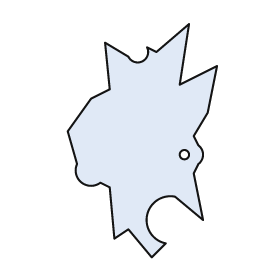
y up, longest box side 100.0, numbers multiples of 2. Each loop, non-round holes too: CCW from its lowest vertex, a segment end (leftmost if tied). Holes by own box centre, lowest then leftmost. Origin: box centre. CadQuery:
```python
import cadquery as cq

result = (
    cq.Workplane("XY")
    .moveTo(4.0, -50.0)
    .lineTo(10.0, -44.0)
    .threePointArc((2.0, -32.0), (14.0, -24.0))
    .lineTo(26.0, -34.0)
    .lineTo(22.0, -14.0)
    .lineTo(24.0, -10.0)
    .threePointArc((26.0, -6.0), (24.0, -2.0))
    .lineTo(22.0, 2.0)
    .lineTo(28.0, 12.0)
    .lineTo(32.0, 32.0)
    .lineTo(16.0, 24.0)
    .lineTo(20.0, 50.0)
    .lineTo(6.0, 38.0)
    .lineTo(2.0, 40.0)
    .threePointArc((0.0, 34.0), (-6.0, 36.0))
    .lineTo(-16.0, 42.0)
    .lineTo(-14.0, 22.0)
    .lineTo(-22.0, 18.0)
    .lineTo(-32.0, 4.0)
    .lineTo(-28.0, -10.0)
    .threePointArc((-26.0, -18.0), (-18.0, -18.0))
    .lineTo(-14.0, -20.0)
    .lineTo(-12.0, -42.0)
    .lineTo(-6.0, -38.0)
    .close()
    .moveTo(18.0, -6.0)
    .circle(2.0)
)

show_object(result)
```